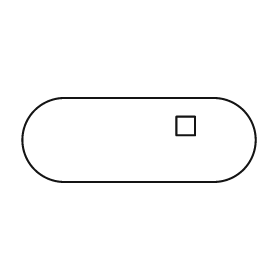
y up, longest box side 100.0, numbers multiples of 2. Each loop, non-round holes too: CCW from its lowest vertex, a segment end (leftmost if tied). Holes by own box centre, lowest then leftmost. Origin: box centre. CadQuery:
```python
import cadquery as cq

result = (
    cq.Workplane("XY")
    .moveTo(-32.0, -18.0)
    .lineTo(32.0, -18.0)
    .threePointArc((50.0, 0.0), (32.0, 18.0))
    .lineTo(-32.0, 18.0)
    .threePointArc((-50.0, 0.0), (-32.0, -18.0))
    .close()
    .moveTo(16.0, 2.0)
    .lineTo(24.0, 2.0)
    .lineTo(24.0, 10.0)
    .lineTo(16.0, 10.0)
    .close()
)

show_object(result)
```